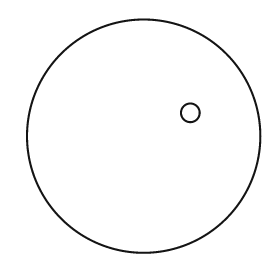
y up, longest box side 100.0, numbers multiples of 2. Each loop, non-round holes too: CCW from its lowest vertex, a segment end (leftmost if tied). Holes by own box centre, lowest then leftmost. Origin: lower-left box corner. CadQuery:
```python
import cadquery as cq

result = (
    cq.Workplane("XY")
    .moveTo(50.0, 50.0)
    .circle(50.0)
    .moveTo(70.0, 60.0)
    .circle(4.0)
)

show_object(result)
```